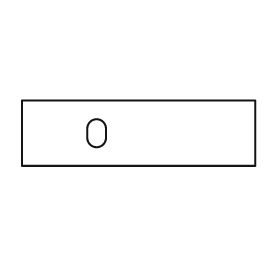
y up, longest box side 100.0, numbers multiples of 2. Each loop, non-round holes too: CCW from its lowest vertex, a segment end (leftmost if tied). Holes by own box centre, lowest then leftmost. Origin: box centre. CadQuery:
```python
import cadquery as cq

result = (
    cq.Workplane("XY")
    .moveTo(-50.0, -14.0)
    .lineTo(50.0, -14.0)
    .lineTo(50.0, 14.0)
    .lineTo(-50.0, 14.0)
    .close()
    .moveTo(-22.0, -2.0)
    .threePointArc((-18.0, -6.0), (-14.0, -2.0))
    .lineTo(-14.0, 2.0)
    .threePointArc((-18.0, 6.0), (-22.0, 2.0))
    .close()
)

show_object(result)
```